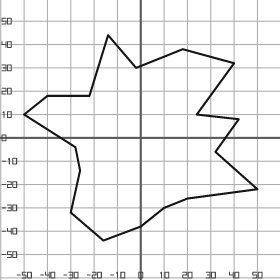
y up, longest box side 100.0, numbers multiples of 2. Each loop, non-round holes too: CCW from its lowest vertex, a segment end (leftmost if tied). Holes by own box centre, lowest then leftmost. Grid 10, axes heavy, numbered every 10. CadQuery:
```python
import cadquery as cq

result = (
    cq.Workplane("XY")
    .moveTo(-16.0, -44.0)
    .lineTo(0.0, -38.0)
    .lineTo(10.0, -30.0)
    .lineTo(20.0, -26.0)
    .lineTo(50.0, -22.0)
    .lineTo(32.0, -6.0)
    .lineTo(42.0, 8.0)
    .lineTo(24.0, 10.0)
    .lineTo(40.0, 32.0)
    .lineTo(18.0, 38.0)
    .lineTo(-2.0, 30.0)
    .lineTo(-14.0, 44.0)
    .lineTo(-22.0, 18.0)
    .lineTo(-40.0, 18.0)
    .lineTo(-50.0, 10.0)
    .lineTo(-28.0, -4.0)
    .lineTo(-26.0, -14.0)
    .lineTo(-30.0, -32.0)
    .close()
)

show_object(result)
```